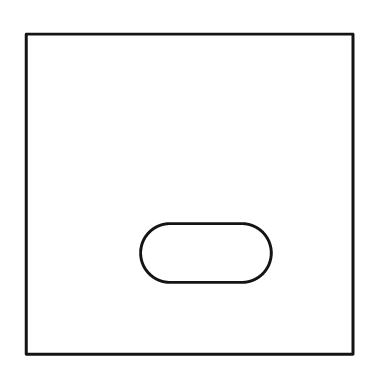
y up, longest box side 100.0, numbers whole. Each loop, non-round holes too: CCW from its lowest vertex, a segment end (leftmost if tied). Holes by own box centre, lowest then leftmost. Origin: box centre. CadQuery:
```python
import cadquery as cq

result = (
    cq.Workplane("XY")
    .moveTo(-50.0, -49.0)
    .lineTo(50.0, -49.0)
    .lineTo(50.0, 49.0)
    .lineTo(-50.0, 49.0)
    .close()
    .moveTo(-6.0, -27.0)
    .lineTo(16.0, -27.0)
    .threePointArc((25.0, -18.0), (16.0, -9.0))
    .lineTo(-6.0, -9.0)
    .threePointArc((-15.0, -18.0), (-6.0, -27.0))
    .close()
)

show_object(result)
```